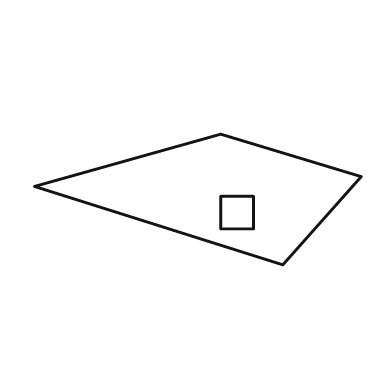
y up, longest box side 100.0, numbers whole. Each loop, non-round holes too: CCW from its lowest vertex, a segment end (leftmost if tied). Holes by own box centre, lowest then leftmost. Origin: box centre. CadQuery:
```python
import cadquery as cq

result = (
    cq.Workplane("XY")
    .moveTo(26.0, -20.0)
    .lineTo(50.0, 7.0)
    .lineTo(7.0, 20.0)
    .lineTo(-50.0, 4.0)
    .close()
    .moveTo(7.0, -9.0)
    .lineTo(17.0, -9.0)
    .lineTo(17.0, 1.0)
    .lineTo(7.0, 1.0)
    .close()
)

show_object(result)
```